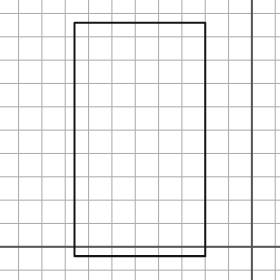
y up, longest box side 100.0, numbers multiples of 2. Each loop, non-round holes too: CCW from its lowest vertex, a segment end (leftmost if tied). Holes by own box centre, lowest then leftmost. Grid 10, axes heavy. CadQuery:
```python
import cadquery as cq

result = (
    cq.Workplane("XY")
    .moveTo(-76.0, -4.0)
    .lineTo(-20.0, -4.0)
    .lineTo(-20.0, 96.0)
    .lineTo(-76.0, 96.0)
    .close()
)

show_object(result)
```